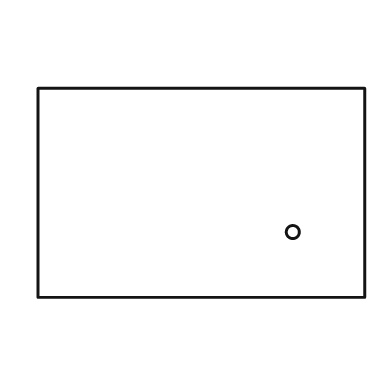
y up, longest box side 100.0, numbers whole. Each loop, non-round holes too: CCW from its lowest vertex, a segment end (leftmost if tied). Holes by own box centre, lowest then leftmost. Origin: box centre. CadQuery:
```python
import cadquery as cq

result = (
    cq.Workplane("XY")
    .moveTo(-50.0, -32.0)
    .lineTo(50.0, -32.0)
    .lineTo(50.0, 32.0)
    .lineTo(-50.0, 32.0)
    .close()
    .moveTo(28.0, -12.0)
    .circle(2.0)
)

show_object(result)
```